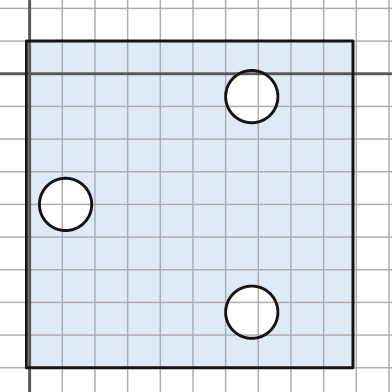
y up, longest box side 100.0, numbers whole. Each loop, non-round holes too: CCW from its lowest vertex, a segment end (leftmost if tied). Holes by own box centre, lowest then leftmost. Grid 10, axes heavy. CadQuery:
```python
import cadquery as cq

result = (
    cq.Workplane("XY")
    .moveTo(-1.0, -90.0)
    .lineTo(99.0, -90.0)
    .lineTo(99.0, 10.0)
    .lineTo(-1.0, 10.0)
    .close()
    .moveTo(68.0, -73.0)
    .circle(8.0)
    .moveTo(11.0, -40.0)
    .circle(8.0)
    .moveTo(68.0, -7.0)
    .circle(8.0)
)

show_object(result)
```